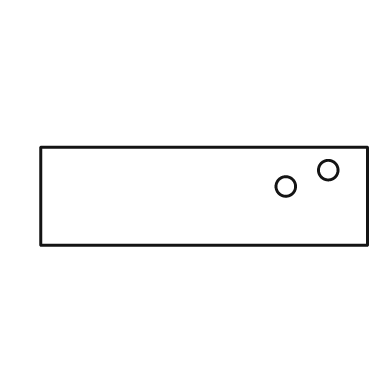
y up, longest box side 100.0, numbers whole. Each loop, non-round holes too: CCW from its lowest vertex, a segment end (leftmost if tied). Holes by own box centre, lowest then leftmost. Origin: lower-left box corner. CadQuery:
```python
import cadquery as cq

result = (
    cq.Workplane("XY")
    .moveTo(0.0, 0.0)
    .lineTo(100.0, 0.0)
    .lineTo(100.0, 30.0)
    .lineTo(0.0, 30.0)
    .close()
    .moveTo(75.0, 18.0)
    .circle(3.0)
    .moveTo(88.0, 23.0)
    .circle(3.0)
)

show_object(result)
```